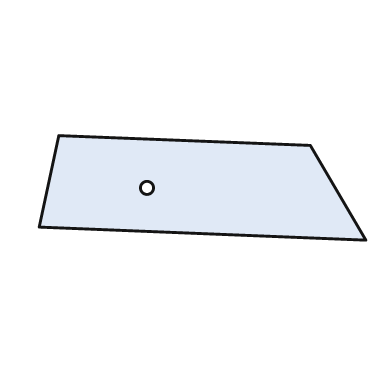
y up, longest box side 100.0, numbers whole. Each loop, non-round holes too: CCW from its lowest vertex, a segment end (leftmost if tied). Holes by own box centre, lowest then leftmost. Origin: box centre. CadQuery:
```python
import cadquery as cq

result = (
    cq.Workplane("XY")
    .moveTo(50.0, -16.0)
    .lineTo(33.0, 13.0)
    .lineTo(-44.0, 16.0)
    .lineTo(-50.0, -12.0)
    .close()
    .moveTo(-17.0, 0.0)
    .circle(2.0)
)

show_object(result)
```